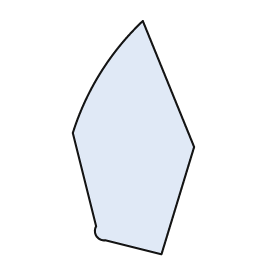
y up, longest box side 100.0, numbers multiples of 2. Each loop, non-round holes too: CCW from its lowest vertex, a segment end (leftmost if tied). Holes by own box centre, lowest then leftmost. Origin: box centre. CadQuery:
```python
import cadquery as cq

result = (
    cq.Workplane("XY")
    .moveTo(12.0, -50.0)
    .lineTo(26.0, -4.0)
    .lineTo(4.0, 50.0)
    .threePointArc((-14.0, 28.0), (-26.0, 2.0))
    .lineTo(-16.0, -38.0)
    .threePointArc((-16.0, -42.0), (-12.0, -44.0))
    .close()
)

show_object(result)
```